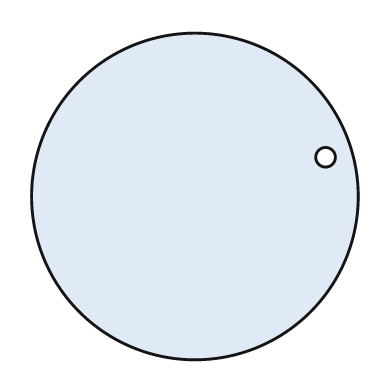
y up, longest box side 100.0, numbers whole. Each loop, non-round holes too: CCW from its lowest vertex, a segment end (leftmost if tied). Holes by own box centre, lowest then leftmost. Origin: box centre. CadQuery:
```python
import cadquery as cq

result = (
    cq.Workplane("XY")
    .moveTo(0.0, 0.0)
    .circle(50.0)
    .moveTo(40.0, 12.0)
    .circle(3.0)
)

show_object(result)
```